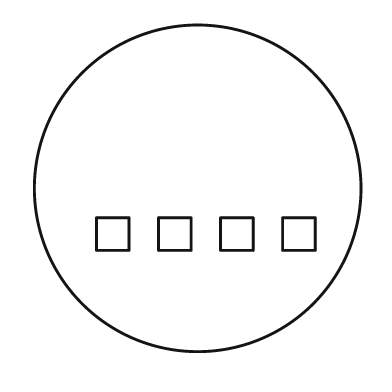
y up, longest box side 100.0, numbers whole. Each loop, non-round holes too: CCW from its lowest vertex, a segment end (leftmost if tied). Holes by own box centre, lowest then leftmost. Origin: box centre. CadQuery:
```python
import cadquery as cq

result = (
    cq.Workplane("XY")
    .moveTo(0.0, 0.0)
    .circle(50.0)
    .moveTo(-31.0, -19.0)
    .lineTo(-21.0, -19.0)
    .lineTo(-21.0, -9.0)
    .lineTo(-31.0, -9.0)
    .close()
    .moveTo(-12.0, -19.0)
    .lineTo(-2.0, -19.0)
    .lineTo(-2.0, -9.0)
    .lineTo(-12.0, -9.0)
    .close()
    .moveTo(7.0, -19.0)
    .lineTo(17.0, -19.0)
    .lineTo(17.0, -9.0)
    .lineTo(7.0, -9.0)
    .close()
    .moveTo(26.0, -19.0)
    .lineTo(36.0, -19.0)
    .lineTo(36.0, -9.0)
    .lineTo(26.0, -9.0)
    .close()
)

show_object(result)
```